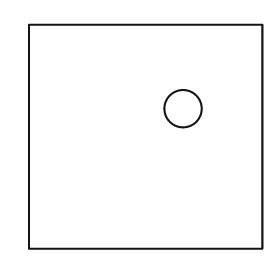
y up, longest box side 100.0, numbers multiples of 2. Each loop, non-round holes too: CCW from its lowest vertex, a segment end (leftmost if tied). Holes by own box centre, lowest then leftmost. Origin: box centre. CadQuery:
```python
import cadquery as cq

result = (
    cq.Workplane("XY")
    .moveTo(-50.0, -48.0)
    .lineTo(50.0, -48.0)
    .lineTo(50.0, 48.0)
    .lineTo(-50.0, 48.0)
    .close()
    .moveTo(16.0, 12.0)
    .circle(8.0)
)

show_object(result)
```